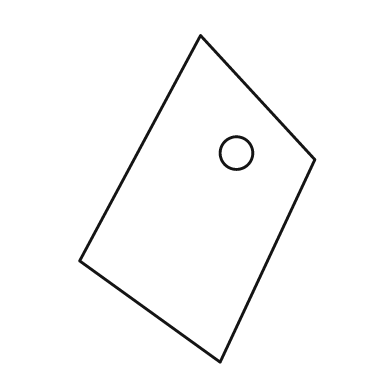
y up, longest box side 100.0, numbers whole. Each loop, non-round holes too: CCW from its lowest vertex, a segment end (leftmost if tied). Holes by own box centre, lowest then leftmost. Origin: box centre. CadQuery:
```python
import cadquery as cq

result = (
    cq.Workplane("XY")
    .moveTo(7.0, -50.0)
    .lineTo(36.0, 12.0)
    .lineTo(1.0, 50.0)
    .lineTo(-36.0, -19.0)
    .close()
    .moveTo(12.0, 14.0)
    .circle(5.0)
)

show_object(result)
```